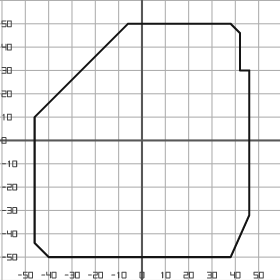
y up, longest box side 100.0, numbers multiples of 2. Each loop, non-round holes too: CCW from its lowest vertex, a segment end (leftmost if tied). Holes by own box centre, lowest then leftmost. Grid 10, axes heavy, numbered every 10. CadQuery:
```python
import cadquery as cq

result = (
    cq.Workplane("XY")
    .moveTo(-40.0, -50.0)
    .lineTo(38.0, -50.0)
    .lineTo(46.0, -32.0)
    .lineTo(46.0, 30.0)
    .lineTo(42.0, 30.0)
    .lineTo(42.0, 46.0)
    .lineTo(38.0, 50.0)
    .lineTo(-6.0, 50.0)
    .lineTo(-46.0, 10.0)
    .lineTo(-46.0, -44.0)
    .close()
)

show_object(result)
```